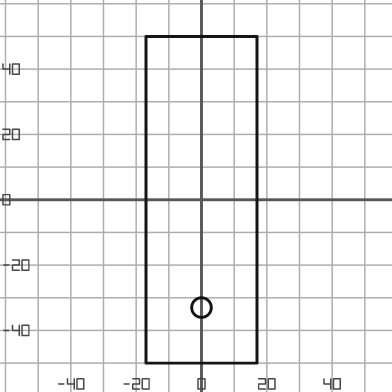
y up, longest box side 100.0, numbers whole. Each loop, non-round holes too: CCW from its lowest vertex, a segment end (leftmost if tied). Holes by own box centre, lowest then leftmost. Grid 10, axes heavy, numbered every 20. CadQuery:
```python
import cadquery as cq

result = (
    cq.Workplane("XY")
    .moveTo(-17.0, -50.0)
    .lineTo(17.0, -50.0)
    .lineTo(17.0, 50.0)
    .lineTo(-17.0, 50.0)
    .close()
    .moveTo(0.0, -33.0)
    .circle(3.0)
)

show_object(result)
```